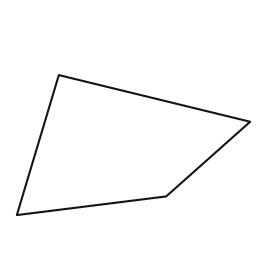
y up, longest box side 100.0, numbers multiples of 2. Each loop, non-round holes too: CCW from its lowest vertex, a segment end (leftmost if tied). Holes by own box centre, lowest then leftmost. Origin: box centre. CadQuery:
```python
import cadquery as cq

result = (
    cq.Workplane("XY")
    .moveTo(-50.0, -30.0)
    .lineTo(14.0, -22.0)
    .lineTo(50.0, 10.0)
    .lineTo(-32.0, 30.0)
    .close()
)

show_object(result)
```